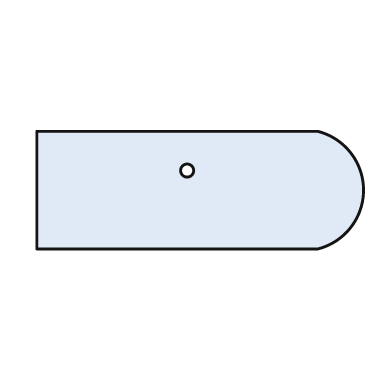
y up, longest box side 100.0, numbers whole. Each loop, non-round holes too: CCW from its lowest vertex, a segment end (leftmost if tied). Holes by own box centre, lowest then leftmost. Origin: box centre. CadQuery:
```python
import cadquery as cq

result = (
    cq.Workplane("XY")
    .moveTo(-50.0, -18.0)
    .lineTo(36.0, -18.0)
    .threePointArc((50.0, 0.0), (36.0, 18.0))
    .lineTo(-50.0, 18.0)
    .close()
    .moveTo(-4.0, 6.0)
    .circle(2.0)
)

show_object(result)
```